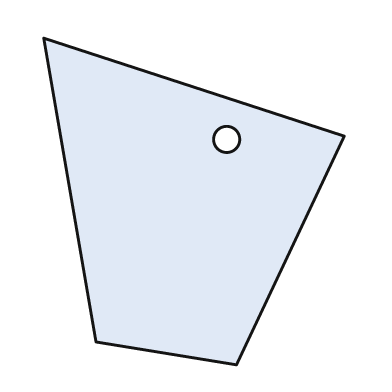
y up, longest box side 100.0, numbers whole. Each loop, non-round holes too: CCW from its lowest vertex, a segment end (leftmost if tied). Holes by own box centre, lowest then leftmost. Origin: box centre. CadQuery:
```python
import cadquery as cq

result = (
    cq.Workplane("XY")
    .moveTo(13.0, -50.0)
    .lineTo(46.0, 20.0)
    .lineTo(-46.0, 50.0)
    .lineTo(-30.0, -43.0)
    .close()
    .moveTo(10.0, 19.0)
    .circle(4.0)
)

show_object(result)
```